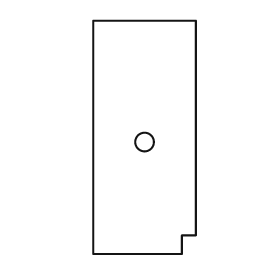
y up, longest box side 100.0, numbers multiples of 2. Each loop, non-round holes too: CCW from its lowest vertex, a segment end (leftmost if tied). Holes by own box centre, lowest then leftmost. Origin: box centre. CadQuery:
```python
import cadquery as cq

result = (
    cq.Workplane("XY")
    .moveTo(-22.0, -50.0)
    .lineTo(16.0, -50.0)
    .lineTo(16.0, -42.0)
    .lineTo(22.0, -42.0)
    .lineTo(22.0, 50.0)
    .lineTo(-22.0, 50.0)
    .close()
    .moveTo(0.0, -2.0)
    .circle(4.0)
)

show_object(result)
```